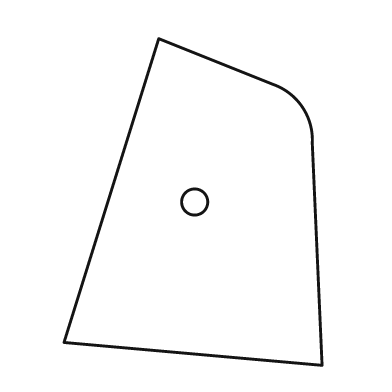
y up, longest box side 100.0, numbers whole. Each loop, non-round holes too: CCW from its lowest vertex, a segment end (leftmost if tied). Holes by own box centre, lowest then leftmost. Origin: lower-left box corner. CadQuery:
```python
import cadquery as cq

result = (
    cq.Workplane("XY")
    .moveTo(79.0, 0.0)
    .lineTo(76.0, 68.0)
    .threePointArc((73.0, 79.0), (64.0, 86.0))
    .lineTo(29.0, 100.0)
    .lineTo(0.0, 7.0)
    .close()
    .moveTo(40.0, 50.0)
    .circle(4.0)
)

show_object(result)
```